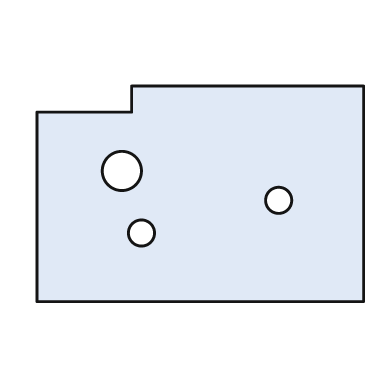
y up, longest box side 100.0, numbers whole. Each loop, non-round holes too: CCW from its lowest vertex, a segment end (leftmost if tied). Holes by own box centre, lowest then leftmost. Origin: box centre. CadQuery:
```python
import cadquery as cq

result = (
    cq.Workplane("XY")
    .moveTo(-50.0, -33.0)
    .lineTo(50.0, -33.0)
    .lineTo(50.0, 33.0)
    .lineTo(-21.0, 33.0)
    .lineTo(-21.0, 25.0)
    .lineTo(-50.0, 25.0)
    .close()
    .moveTo(-18.0, -12.0)
    .circle(4.0)
    .moveTo(24.0, -2.0)
    .circle(4.0)
    .moveTo(-24.0, 7.0)
    .circle(6.0)
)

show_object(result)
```